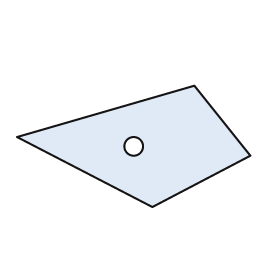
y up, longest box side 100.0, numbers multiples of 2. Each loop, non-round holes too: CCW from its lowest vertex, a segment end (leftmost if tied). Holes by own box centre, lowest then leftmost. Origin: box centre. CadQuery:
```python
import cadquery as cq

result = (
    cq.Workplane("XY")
    .moveTo(8.0, -26.0)
    .lineTo(50.0, -4.0)
    .lineTo(26.0, 26.0)
    .lineTo(-50.0, 4.0)
    .close()
    .moveTo(0.0, 0.0)
    .circle(4.0)
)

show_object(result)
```